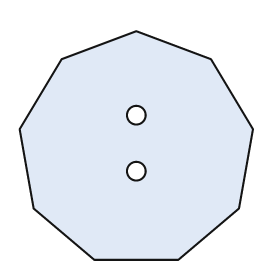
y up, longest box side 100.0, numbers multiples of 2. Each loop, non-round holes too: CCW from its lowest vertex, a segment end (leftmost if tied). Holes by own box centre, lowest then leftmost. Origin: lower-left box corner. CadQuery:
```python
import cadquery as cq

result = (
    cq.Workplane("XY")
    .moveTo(32.0, 0.0)
    .lineTo(68.0, 0.0)
    .lineTo(94.0, 22.0)
    .lineTo(100.0, 56.0)
    .lineTo(82.0, 86.0)
    .lineTo(50.0, 98.0)
    .lineTo(18.0, 86.0)
    .lineTo(0.0, 56.0)
    .lineTo(6.0, 22.0)
    .close()
    .moveTo(50.0, 38.0)
    .circle(4.0)
    .moveTo(50.0, 62.0)
    .circle(4.0)
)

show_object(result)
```